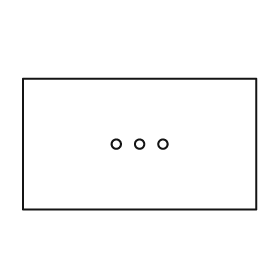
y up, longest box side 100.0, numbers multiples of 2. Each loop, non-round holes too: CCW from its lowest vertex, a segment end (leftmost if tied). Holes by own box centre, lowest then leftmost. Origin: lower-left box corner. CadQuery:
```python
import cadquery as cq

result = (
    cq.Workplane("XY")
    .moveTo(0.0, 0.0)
    .lineTo(100.0, 0.0)
    .lineTo(100.0, 56.0)
    .lineTo(0.0, 56.0)
    .close()
    .moveTo(40.0, 28.0)
    .circle(2.0)
    .moveTo(50.0, 28.0)
    .circle(2.0)
    .moveTo(60.0, 28.0)
    .circle(2.0)
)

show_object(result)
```